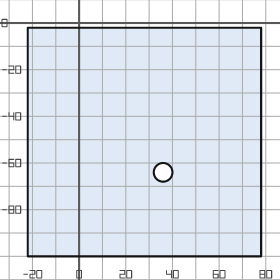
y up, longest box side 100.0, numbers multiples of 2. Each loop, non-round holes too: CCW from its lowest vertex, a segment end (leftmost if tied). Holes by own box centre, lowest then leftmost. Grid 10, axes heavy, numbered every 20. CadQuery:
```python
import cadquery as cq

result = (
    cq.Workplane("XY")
    .moveTo(-22.0, -100.0)
    .lineTo(78.0, -100.0)
    .lineTo(78.0, -2.0)
    .lineTo(-22.0, -2.0)
    .close()
    .moveTo(36.0, -64.0)
    .circle(4.0)
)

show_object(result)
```